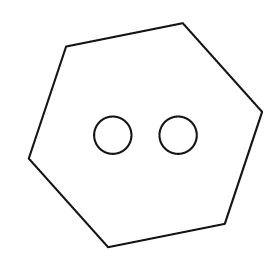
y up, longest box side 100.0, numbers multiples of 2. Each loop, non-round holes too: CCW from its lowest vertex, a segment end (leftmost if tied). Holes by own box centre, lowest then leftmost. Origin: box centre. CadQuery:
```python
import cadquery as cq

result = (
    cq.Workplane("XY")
    .moveTo(-16.0, -48.0)
    .lineTo(34.0, -38.0)
    .lineTo(50.0, 10.0)
    .lineTo(16.0, 48.0)
    .lineTo(-34.0, 38.0)
    .lineTo(-50.0, -10.0)
    .close()
    .moveTo(-14.0, 0.0)
    .circle(8.0)
    .moveTo(14.0, 0.0)
    .circle(8.0)
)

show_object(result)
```